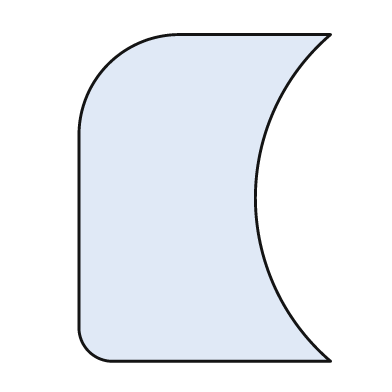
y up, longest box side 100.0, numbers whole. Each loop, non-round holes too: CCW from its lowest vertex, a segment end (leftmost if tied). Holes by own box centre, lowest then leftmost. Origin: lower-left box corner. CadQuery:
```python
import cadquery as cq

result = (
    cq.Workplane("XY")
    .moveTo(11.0, 0.0)
    .lineTo(77.0, 0.0)
    .threePointArc((54.0, 50.0), (77.0, 100.0))
    .lineTo(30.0, 100.0)
    .threePointArc((9.0, 91.0), (0.0, 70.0))
    .lineTo(0.0, 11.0)
    .threePointArc((3.0, 3.0), (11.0, 0.0))
    .close()
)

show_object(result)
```